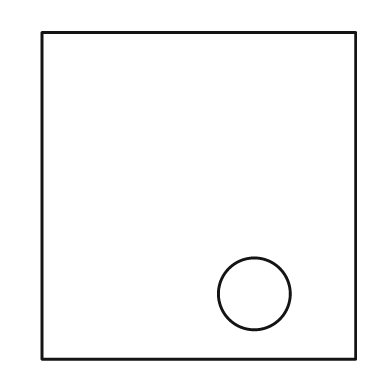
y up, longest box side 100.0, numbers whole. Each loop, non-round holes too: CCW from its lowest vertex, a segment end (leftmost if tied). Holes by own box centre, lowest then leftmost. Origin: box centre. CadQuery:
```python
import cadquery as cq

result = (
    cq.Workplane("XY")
    .moveTo(-48.0, -50.0)
    .lineTo(48.0, -50.0)
    .lineTo(48.0, 50.0)
    .lineTo(-48.0, 50.0)
    .close()
    .moveTo(17.0, -30.0)
    .circle(11.0)
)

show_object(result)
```